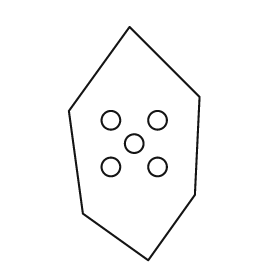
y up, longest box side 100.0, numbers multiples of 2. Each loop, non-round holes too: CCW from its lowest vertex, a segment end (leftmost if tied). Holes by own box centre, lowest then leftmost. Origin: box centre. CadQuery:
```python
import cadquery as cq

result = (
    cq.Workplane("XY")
    .moveTo(6.0, -50.0)
    .lineTo(26.0, -22.0)
    .lineTo(28.0, 20.0)
    .lineTo(-2.0, 50.0)
    .lineTo(-28.0, 14.0)
    .lineTo(-22.0, -30.0)
    .close()
    .moveTo(-10.0, -10.0)
    .circle(4.0)
    .moveTo(10.0, -10.0)
    .circle(4.0)
    .moveTo(0.0, 0.0)
    .circle(4.0)
    .moveTo(-10.0, 10.0)
    .circle(4.0)
    .moveTo(10.0, 10.0)
    .circle(4.0)
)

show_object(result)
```